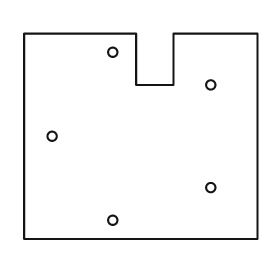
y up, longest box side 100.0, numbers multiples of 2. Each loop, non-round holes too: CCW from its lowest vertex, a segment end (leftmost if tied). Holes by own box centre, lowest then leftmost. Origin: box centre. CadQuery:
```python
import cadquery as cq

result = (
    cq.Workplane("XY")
    .moveTo(-50.0, -44.0)
    .lineTo(50.0, -44.0)
    .lineTo(50.0, 44.0)
    .lineTo(14.0, 44.0)
    .lineTo(14.0, 22.0)
    .lineTo(-2.0, 22.0)
    .lineTo(-2.0, 44.0)
    .lineTo(-50.0, 44.0)
    .close()
    .moveTo(-12.0, -36.0)
    .circle(2.0)
    .moveTo(30.0, -22.0)
    .circle(2.0)
    .moveTo(-38.0, 0.0)
    .circle(2.0)
    .moveTo(30.0, 22.0)
    .circle(2.0)
    .moveTo(-12.0, 36.0)
    .circle(2.0)
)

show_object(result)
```